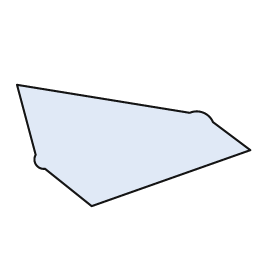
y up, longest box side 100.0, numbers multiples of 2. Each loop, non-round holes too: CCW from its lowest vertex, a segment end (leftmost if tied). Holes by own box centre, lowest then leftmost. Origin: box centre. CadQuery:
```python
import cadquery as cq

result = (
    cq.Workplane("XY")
    .moveTo(-18.0, -26.0)
    .lineTo(50.0, -2.0)
    .lineTo(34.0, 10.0)
    .threePointArc((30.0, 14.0), (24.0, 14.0))
    .lineTo(-50.0, 26.0)
    .lineTo(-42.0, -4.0)
    .threePointArc((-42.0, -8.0), (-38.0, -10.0))
    .close()
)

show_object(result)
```